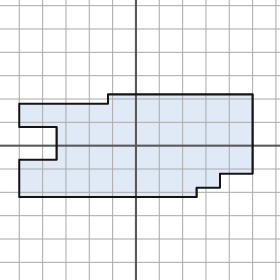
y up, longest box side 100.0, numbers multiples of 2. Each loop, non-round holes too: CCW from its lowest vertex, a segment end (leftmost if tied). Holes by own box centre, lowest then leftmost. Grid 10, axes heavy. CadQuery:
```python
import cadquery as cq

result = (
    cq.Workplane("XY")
    .moveTo(-50.0, -22.0)
    .lineTo(26.0, -22.0)
    .lineTo(26.0, -18.0)
    .lineTo(36.0, -18.0)
    .lineTo(36.0, -12.0)
    .lineTo(50.0, -12.0)
    .lineTo(50.0, 22.0)
    .lineTo(-12.0, 22.0)
    .lineTo(-12.0, 18.0)
    .lineTo(-50.0, 18.0)
    .lineTo(-50.0, 8.0)
    .lineTo(-34.0, 8.0)
    .lineTo(-34.0, -6.0)
    .lineTo(-50.0, -6.0)
    .close()
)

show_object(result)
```